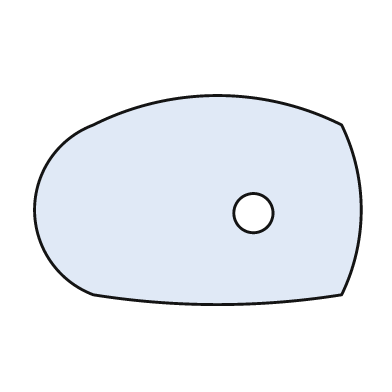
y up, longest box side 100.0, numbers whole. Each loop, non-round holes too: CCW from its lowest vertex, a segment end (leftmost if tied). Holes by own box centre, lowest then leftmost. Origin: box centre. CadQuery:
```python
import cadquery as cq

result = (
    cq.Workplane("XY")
    .moveTo(-32.0, -29.0)
    .threePointArc((6.0, -32.0), (44.0, -29.0))
    .threePointArc((50.0, -3.0), (44.0, 23.0))
    .threePointArc((6.0, 32.0), (-32.0, 23.0))
    .threePointArc((-50.0, -3.0), (-32.0, -29.0))
    .close()
    .moveTo(17.0, -4.0)
    .circle(6.0)
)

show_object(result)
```